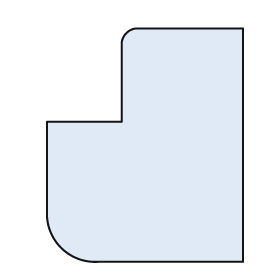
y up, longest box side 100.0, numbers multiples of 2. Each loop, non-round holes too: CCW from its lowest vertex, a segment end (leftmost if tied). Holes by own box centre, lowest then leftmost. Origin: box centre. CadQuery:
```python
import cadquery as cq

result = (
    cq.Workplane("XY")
    .moveTo(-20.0, -50.0)
    .lineTo(42.0, -50.0)
    .lineTo(42.0, 50.0)
    .lineTo(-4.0, 50.0)
    .threePointArc((-8.0, 48.0), (-10.0, 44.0))
    .lineTo(-10.0, 10.0)
    .lineTo(-42.0, 10.0)
    .lineTo(-42.0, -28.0)
    .threePointArc((-36.0, -44.0), (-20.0, -50.0))
    .close()
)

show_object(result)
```